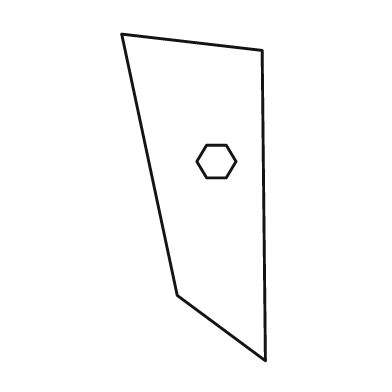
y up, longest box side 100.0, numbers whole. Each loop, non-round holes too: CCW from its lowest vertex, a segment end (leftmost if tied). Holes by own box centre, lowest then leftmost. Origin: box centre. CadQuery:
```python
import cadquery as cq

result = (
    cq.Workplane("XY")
    .moveTo(22.0, -50.0)
    .lineTo(21.0, 45.0)
    .lineTo(-22.0, 50.0)
    .lineTo(-5.0, -30.0)
    .close()
    .moveTo(4.0, 6.0)
    .lineTo(10.0, 6.0)
    .lineTo(13.0, 11.0)
    .lineTo(10.0, 16.0)
    .lineTo(4.0, 16.0)
    .lineTo(1.0, 11.0)
    .close()
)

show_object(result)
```